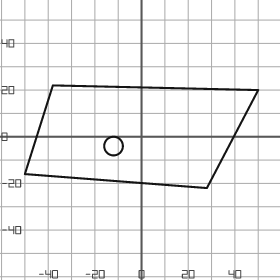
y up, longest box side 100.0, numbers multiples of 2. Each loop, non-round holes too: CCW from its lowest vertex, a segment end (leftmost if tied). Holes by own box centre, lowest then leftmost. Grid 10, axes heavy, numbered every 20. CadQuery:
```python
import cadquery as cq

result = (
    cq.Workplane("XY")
    .moveTo(28.0, -22.0)
    .lineTo(50.0, 20.0)
    .lineTo(-38.0, 22.0)
    .lineTo(-50.0, -16.0)
    .close()
    .moveTo(-12.0, -4.0)
    .circle(4.0)
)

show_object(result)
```